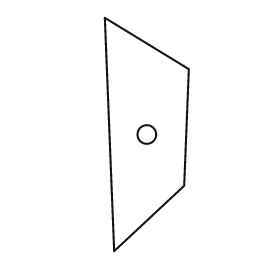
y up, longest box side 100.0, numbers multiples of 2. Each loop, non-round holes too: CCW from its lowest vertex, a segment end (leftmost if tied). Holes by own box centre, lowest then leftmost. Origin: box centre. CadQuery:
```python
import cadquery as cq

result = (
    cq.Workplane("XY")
    .moveTo(-14.0, -50.0)
    .lineTo(16.0, -22.0)
    .lineTo(18.0, 28.0)
    .lineTo(-18.0, 50.0)
    .close()
    .moveTo(0.0, 0.0)
    .circle(4.0)
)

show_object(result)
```